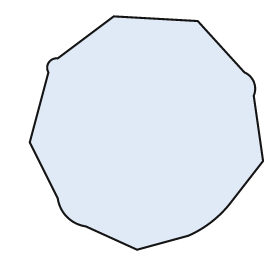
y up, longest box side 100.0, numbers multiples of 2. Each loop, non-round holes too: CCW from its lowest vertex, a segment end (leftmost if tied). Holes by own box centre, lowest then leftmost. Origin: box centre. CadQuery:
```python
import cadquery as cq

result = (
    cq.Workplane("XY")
    .moveTo(-4.0, -50.0)
    .lineTo(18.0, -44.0)
    .threePointArc((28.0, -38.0), (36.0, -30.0))
    .lineTo(50.0, -12.0)
    .lineTo(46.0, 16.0)
    .threePointArc((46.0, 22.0), (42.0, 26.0))
    .lineTo(22.0, 48.0)
    .lineTo(-14.0, 50.0)
    .lineTo(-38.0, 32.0)
    .threePointArc((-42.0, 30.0), (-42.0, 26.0))
    .lineTo(-50.0, -4.0)
    .lineTo(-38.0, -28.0)
    .threePointArc((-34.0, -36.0), (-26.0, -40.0))
    .close()
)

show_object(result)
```